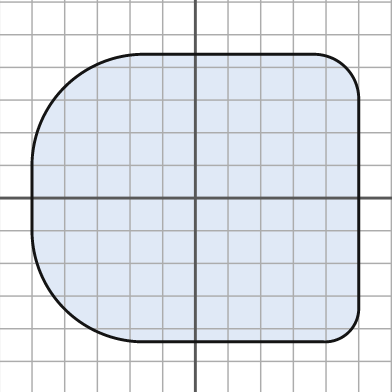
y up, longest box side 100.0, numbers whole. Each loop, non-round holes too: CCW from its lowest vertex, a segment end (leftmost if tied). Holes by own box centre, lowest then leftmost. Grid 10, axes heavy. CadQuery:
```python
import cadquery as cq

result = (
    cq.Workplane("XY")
    .moveTo(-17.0, -44.0)
    .lineTo(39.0, -44.0)
    .threePointArc((47.0, -41.0), (50.0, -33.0))
    .lineTo(50.0, 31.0)
    .threePointArc((46.0, 40.0), (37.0, 44.0))
    .lineTo(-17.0, 44.0)
    .threePointArc((-40.0, 34.0), (-50.0, 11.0))
    .lineTo(-50.0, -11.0)
    .threePointArc((-40.0, -34.0), (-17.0, -44.0))
    .close()
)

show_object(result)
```